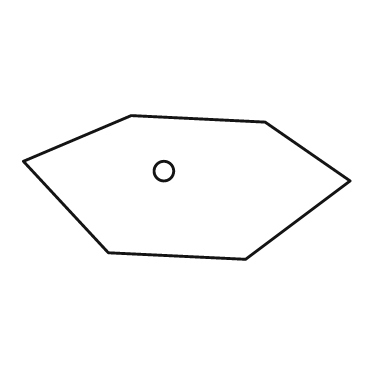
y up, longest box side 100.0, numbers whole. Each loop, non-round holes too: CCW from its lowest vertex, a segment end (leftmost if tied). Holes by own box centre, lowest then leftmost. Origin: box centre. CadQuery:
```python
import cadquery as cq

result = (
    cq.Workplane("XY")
    .moveTo(18.0, -22.0)
    .lineTo(50.0, 2.0)
    .lineTo(24.0, 20.0)
    .lineTo(-17.0, 22.0)
    .lineTo(-50.0, 8.0)
    .lineTo(-24.0, -20.0)
    .close()
    .moveTo(-7.0, 5.0)
    .circle(3.0)
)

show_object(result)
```